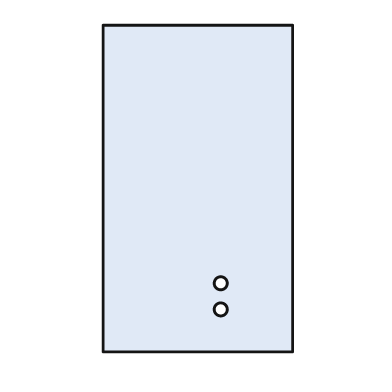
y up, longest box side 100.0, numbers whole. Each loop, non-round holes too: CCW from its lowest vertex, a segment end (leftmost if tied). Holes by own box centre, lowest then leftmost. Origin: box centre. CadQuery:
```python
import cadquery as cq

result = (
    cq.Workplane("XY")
    .moveTo(-29.0, -50.0)
    .lineTo(29.0, -50.0)
    .lineTo(29.0, 50.0)
    .lineTo(-29.0, 50.0)
    .close()
    .moveTo(7.0, -37.0)
    .circle(2.0)
    .moveTo(7.0, -29.0)
    .circle(2.0)
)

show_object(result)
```